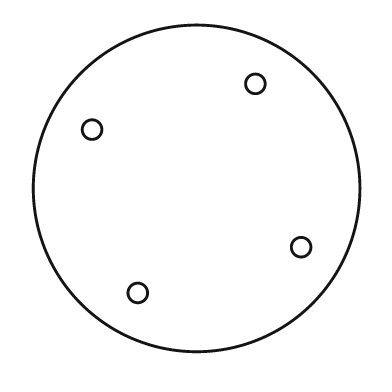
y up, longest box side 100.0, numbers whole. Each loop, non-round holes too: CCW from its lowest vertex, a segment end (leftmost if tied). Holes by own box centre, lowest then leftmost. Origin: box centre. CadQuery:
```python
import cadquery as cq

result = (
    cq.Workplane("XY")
    .moveTo(0.0, 0.0)
    .circle(50.0)
    .moveTo(-18.0, -32.0)
    .circle(3.0)
    .moveTo(32.0, -18.0)
    .circle(3.0)
    .moveTo(-32.0, 18.0)
    .circle(3.0)
    .moveTo(18.0, 32.0)
    .circle(3.0)
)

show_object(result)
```